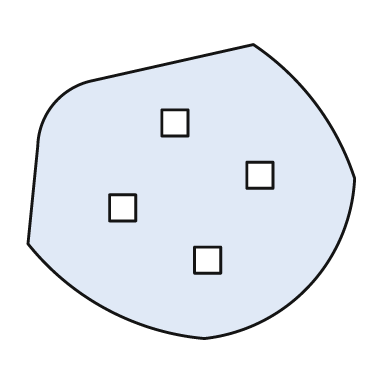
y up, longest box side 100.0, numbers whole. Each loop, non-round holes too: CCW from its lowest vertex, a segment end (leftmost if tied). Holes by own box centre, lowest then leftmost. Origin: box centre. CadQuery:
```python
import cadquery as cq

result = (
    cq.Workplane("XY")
    .moveTo(4.0, -45.0)
    .threePointArc((36.0, -29.0), (50.0, 4.0))
    .threePointArc((38.0, 27.0), (19.0, 45.0))
    .lineTo(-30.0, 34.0)
    .threePointArc((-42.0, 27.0), (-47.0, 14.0))
    .lineTo(-50.0, -16.0)
    .threePointArc((-26.0, -36.0), (4.0, -45.0))
    .close()
    .moveTo(1.0, -25.0)
    .lineTo(9.0, -25.0)
    .lineTo(9.0, -17.0)
    .lineTo(1.0, -17.0)
    .close()
    .moveTo(-25.0, -9.0)
    .lineTo(-17.0, -9.0)
    .lineTo(-17.0, -1.0)
    .lineTo(-25.0, -1.0)
    .close()
    .moveTo(17.0, 1.0)
    .lineTo(25.0, 1.0)
    .lineTo(25.0, 9.0)
    .lineTo(17.0, 9.0)
    .close()
    .moveTo(-9.0, 17.0)
    .lineTo(-1.0, 17.0)
    .lineTo(-1.0, 25.0)
    .lineTo(-9.0, 25.0)
    .close()
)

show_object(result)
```